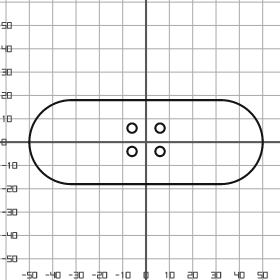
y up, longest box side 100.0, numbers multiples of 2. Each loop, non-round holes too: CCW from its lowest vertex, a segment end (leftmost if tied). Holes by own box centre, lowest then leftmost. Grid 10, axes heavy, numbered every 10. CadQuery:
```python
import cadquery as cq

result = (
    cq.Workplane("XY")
    .moveTo(-32.0, -18.0)
    .lineTo(32.0, -18.0)
    .threePointArc((50.0, 0.0), (32.0, 18.0))
    .lineTo(-32.0, 18.0)
    .threePointArc((-50.0, 0.0), (-32.0, -18.0))
    .close()
    .moveTo(-6.0, -4.0)
    .circle(2.0)
    .moveTo(6.0, -4.0)
    .circle(2.0)
    .moveTo(-6.0, 6.0)
    .circle(2.0)
    .moveTo(6.0, 6.0)
    .circle(2.0)
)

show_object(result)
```